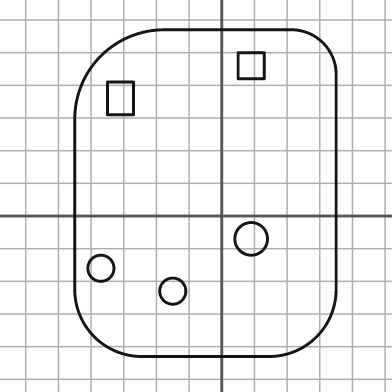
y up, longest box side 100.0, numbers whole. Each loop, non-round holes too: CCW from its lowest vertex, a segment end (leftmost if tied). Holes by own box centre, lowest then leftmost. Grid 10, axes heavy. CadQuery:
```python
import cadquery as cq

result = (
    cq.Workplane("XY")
    .moveTo(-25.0, -43.0)
    .lineTo(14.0, -43.0)
    .threePointArc((29.0, -37.0), (35.0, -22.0))
    .lineTo(35.0, 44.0)
    .threePointArc((31.0, 53.0), (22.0, 57.0))
    .lineTo(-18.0, 57.0)
    .threePointArc((-37.0, 49.0), (-45.0, 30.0))
    .lineTo(-45.0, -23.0)
    .threePointArc((-39.0, -37.0), (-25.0, -43.0))
    .close()
    .moveTo(-15.0, -23.0)
    .circle(4.0)
    .moveTo(-37.0, -16.0)
    .circle(4.0)
    .moveTo(9.0, -7.0)
    .circle(5.0)
    .moveTo(-35.0, 31.0)
    .lineTo(-27.0, 31.0)
    .lineTo(-27.0, 41.0)
    .lineTo(-35.0, 41.0)
    .close()
    .moveTo(5.0, 42.0)
    .lineTo(13.0, 42.0)
    .lineTo(13.0, 50.0)
    .lineTo(5.0, 50.0)
    .close()
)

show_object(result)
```